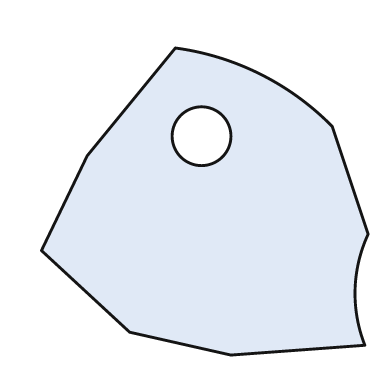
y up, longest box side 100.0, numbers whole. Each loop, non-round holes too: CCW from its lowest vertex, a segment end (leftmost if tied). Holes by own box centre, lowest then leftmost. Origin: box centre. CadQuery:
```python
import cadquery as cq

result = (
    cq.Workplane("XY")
    .moveTo(8.0, -47.0)
    .lineTo(49.0, -44.0)
    .threePointArc((46.0, -27.0), (50.0, -10.0))
    .lineTo(39.0, 23.0)
    .threePointArc((17.0, 39.0), (-9.0, 47.0))
    .lineTo(-36.0, 14.0)
    .lineTo(-50.0, -15.0)
    .lineTo(-23.0, -40.0)
    .close()
    .moveTo(-1.0, 20.0)
    .circle(9.0)
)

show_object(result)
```